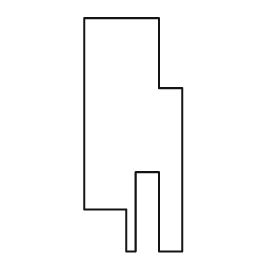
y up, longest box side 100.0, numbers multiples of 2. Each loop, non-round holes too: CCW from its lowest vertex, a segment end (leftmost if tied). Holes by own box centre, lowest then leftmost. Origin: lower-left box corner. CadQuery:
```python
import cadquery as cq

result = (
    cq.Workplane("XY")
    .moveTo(18.0, 0.0)
    .lineTo(22.0, 0.0)
    .lineTo(22.0, 34.0)
    .lineTo(32.0, 34.0)
    .lineTo(32.0, 0.0)
    .lineTo(42.0, 0.0)
    .lineTo(42.0, 70.0)
    .lineTo(32.0, 70.0)
    .lineTo(32.0, 100.0)
    .lineTo(0.0, 100.0)
    .lineTo(0.0, 18.0)
    .lineTo(18.0, 18.0)
    .close()
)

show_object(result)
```